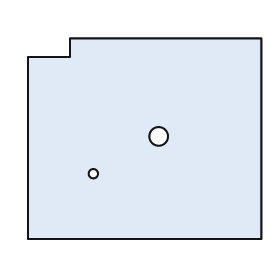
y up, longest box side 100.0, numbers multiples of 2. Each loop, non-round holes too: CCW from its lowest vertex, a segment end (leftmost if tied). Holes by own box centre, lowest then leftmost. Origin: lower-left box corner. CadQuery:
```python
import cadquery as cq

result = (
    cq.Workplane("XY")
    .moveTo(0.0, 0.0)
    .lineTo(100.0, 0.0)
    .lineTo(100.0, 86.0)
    .lineTo(18.0, 86.0)
    .lineTo(18.0, 78.0)
    .lineTo(0.0, 78.0)
    .close()
    .moveTo(28.0, 28.0)
    .circle(2.0)
    .moveTo(56.0, 44.0)
    .circle(4.0)
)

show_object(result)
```